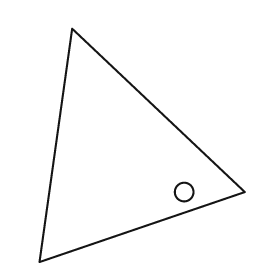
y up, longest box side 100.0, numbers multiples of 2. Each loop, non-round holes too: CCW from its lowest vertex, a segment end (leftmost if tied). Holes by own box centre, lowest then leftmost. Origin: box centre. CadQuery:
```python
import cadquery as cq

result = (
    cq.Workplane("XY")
    .moveTo(-44.0, -50.0)
    .lineTo(44.0, -20.0)
    .lineTo(-30.0, 50.0)
    .close()
    .moveTo(18.0, -20.0)
    .circle(4.0)
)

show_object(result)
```